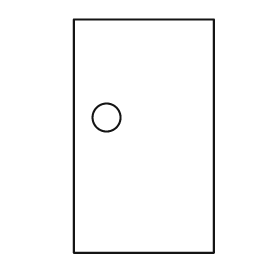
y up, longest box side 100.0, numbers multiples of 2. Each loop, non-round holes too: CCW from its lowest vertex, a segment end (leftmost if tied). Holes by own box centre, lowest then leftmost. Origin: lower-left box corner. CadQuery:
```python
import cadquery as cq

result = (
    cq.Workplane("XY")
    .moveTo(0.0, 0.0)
    .lineTo(60.0, 0.0)
    .lineTo(60.0, 100.0)
    .lineTo(0.0, 100.0)
    .close()
    .moveTo(14.0, 58.0)
    .circle(6.0)
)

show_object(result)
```